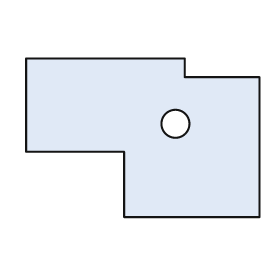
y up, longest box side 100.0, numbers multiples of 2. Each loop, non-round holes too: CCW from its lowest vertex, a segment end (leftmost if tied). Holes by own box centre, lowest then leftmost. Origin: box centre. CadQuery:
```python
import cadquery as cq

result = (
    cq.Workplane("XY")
    .moveTo(-8.0, -34.0)
    .lineTo(50.0, -34.0)
    .lineTo(50.0, 26.0)
    .lineTo(18.0, 26.0)
    .lineTo(18.0, 34.0)
    .lineTo(-50.0, 34.0)
    .lineTo(-50.0, -6.0)
    .lineTo(-8.0, -6.0)
    .close()
    .moveTo(14.0, 6.0)
    .circle(6.0)
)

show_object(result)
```